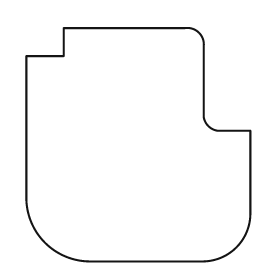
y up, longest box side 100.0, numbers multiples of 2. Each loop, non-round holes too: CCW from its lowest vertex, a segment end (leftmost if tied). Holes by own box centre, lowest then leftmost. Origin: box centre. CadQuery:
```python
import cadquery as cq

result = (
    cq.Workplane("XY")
    .moveTo(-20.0, -50.0)
    .lineTo(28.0, -50.0)
    .threePointArc((42.0, -44.0), (48.0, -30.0))
    .lineTo(48.0, 6.0)
    .lineTo(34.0, 6.0)
    .threePointArc((30.0, 8.0), (28.0, 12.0))
    .lineTo(28.0, 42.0)
    .threePointArc((26.0, 48.0), (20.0, 50.0))
    .lineTo(-32.0, 50.0)
    .lineTo(-32.0, 38.0)
    .lineTo(-48.0, 38.0)
    .lineTo(-48.0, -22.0)
    .threePointArc((-40.0, -42.0), (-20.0, -50.0))
    .close()
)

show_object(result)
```